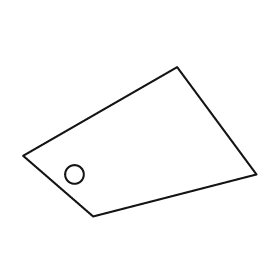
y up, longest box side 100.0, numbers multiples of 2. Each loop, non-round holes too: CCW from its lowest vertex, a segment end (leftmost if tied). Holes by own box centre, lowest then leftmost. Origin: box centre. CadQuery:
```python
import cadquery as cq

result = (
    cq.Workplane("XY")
    .moveTo(-20.0, -32.0)
    .lineTo(50.0, -14.0)
    .lineTo(16.0, 32.0)
    .lineTo(-50.0, -6.0)
    .close()
    .moveTo(-28.0, -14.0)
    .circle(4.0)
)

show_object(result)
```